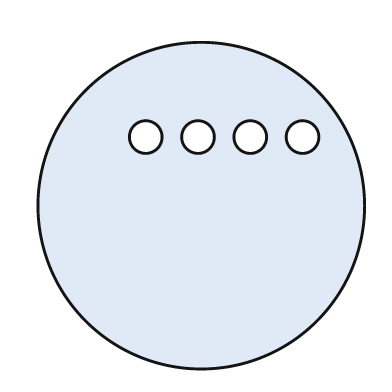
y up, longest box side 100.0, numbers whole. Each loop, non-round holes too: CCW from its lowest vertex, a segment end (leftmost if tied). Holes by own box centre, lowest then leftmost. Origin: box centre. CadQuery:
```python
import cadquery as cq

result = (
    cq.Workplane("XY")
    .moveTo(0.0, 0.0)
    .circle(50.0)
    .moveTo(-17.0, 21.0)
    .circle(5.0)
    .moveTo(-1.0, 21.0)
    .circle(5.0)
    .moveTo(15.0, 21.0)
    .circle(5.0)
    .moveTo(31.0, 21.0)
    .circle(5.0)
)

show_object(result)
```